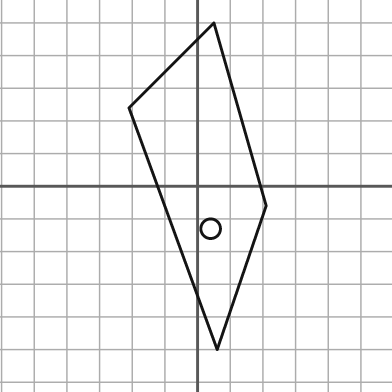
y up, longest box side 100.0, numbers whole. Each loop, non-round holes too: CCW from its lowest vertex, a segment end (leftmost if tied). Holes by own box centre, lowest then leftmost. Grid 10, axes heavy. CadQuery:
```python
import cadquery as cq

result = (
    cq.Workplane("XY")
    .moveTo(6.0, -50.0)
    .lineTo(21.0, -6.0)
    .lineTo(5.0, 50.0)
    .lineTo(-21.0, 24.0)
    .close()
    .moveTo(4.0, -13.0)
    .circle(3.0)
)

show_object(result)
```